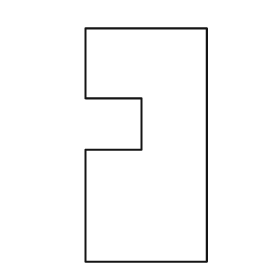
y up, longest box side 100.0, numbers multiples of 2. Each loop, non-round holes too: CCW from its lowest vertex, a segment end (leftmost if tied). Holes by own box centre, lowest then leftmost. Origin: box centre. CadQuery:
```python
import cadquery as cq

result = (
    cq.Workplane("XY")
    .moveTo(-26.0, -50.0)
    .lineTo(26.0, -50.0)
    .lineTo(26.0, 50.0)
    .lineTo(-26.0, 50.0)
    .lineTo(-26.0, 20.0)
    .lineTo(-2.0, 20.0)
    .lineTo(-2.0, -2.0)
    .lineTo(-26.0, -2.0)
    .close()
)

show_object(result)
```